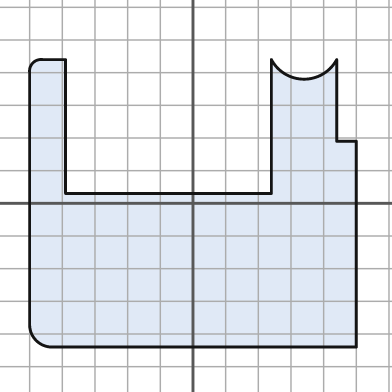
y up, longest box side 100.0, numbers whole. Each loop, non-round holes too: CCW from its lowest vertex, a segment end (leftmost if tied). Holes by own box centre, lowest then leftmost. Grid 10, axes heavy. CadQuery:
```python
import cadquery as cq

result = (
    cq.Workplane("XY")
    .moveTo(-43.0, -44.0)
    .lineTo(50.0, -44.0)
    .lineTo(50.0, 19.0)
    .lineTo(44.0, 19.0)
    .lineTo(44.0, 44.0)
    .threePointArc((34.0, 38.0), (24.0, 44.0))
    .lineTo(24.0, 3.0)
    .lineTo(-39.0, 3.0)
    .lineTo(-39.0, 44.0)
    .lineTo(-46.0, 44.0)
    .threePointArc((-49.0, 43.0), (-50.0, 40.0))
    .lineTo(-50.0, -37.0)
    .threePointArc((-48.0, -42.0), (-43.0, -44.0))
    .close()
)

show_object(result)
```